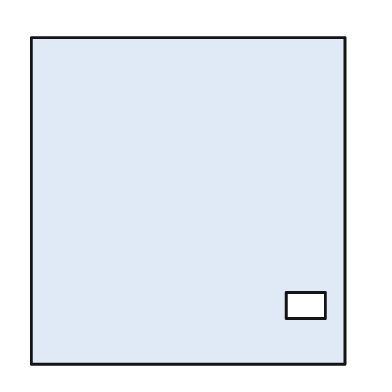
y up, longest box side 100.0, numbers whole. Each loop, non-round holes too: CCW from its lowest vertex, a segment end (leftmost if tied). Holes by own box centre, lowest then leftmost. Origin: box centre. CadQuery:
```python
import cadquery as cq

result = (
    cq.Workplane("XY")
    .moveTo(-48.0, -50.0)
    .lineTo(48.0, -50.0)
    .lineTo(48.0, 50.0)
    .lineTo(-48.0, 50.0)
    .close()
    .moveTo(30.0, -36.0)
    .lineTo(42.0, -36.0)
    .lineTo(42.0, -28.0)
    .lineTo(30.0, -28.0)
    .close()
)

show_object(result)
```